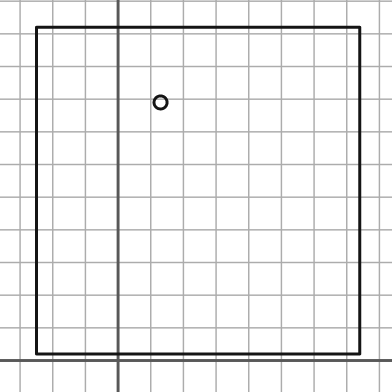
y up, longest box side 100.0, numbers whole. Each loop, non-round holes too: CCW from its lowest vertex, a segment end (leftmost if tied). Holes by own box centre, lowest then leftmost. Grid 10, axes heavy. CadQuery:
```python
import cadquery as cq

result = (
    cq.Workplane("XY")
    .moveTo(-25.0, 2.0)
    .lineTo(74.0, 2.0)
    .lineTo(74.0, 102.0)
    .lineTo(-25.0, 102.0)
    .close()
    .moveTo(13.0, 79.0)
    .circle(2.0)
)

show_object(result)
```